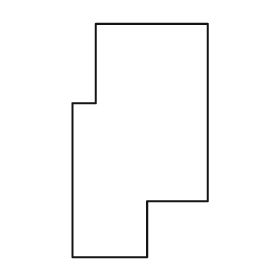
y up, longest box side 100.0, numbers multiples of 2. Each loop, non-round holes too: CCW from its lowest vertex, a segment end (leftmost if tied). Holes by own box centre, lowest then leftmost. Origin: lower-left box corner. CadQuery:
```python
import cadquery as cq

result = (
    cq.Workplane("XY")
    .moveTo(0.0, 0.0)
    .lineTo(32.0, 0.0)
    .lineTo(32.0, 24.0)
    .lineTo(58.0, 24.0)
    .lineTo(58.0, 100.0)
    .lineTo(10.0, 100.0)
    .lineTo(10.0, 66.0)
    .lineTo(0.0, 66.0)
    .close()
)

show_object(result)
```